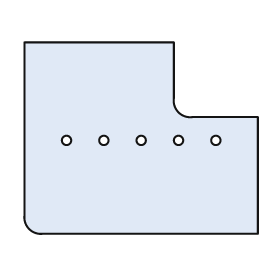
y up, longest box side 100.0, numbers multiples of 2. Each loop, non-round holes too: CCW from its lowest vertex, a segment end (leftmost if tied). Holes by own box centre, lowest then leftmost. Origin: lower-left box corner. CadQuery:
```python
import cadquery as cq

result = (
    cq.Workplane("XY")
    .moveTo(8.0, 0.0)
    .lineTo(100.0, 0.0)
    .lineTo(100.0, 50.0)
    .lineTo(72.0, 50.0)
    .threePointArc((66.0, 52.0), (64.0, 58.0))
    .lineTo(64.0, 82.0)
    .lineTo(0.0, 82.0)
    .lineTo(0.0, 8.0)
    .threePointArc((2.0, 2.0), (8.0, 0.0))
    .close()
    .moveTo(18.0, 40.0)
    .circle(2.0)
    .moveTo(34.0, 40.0)
    .circle(2.0)
    .moveTo(50.0, 40.0)
    .circle(2.0)
    .moveTo(66.0, 40.0)
    .circle(2.0)
    .moveTo(82.0, 40.0)
    .circle(2.0)
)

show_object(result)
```